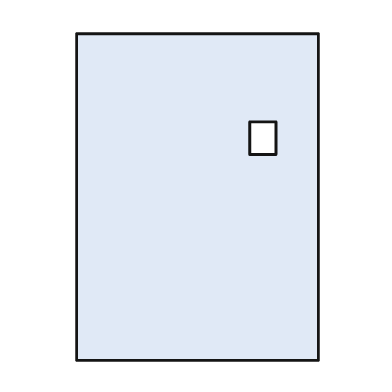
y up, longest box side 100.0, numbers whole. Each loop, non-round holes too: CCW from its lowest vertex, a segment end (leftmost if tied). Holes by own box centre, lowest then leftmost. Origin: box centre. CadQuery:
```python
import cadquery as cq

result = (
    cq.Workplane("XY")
    .moveTo(-37.0, -50.0)
    .lineTo(37.0, -50.0)
    .lineTo(37.0, 50.0)
    .lineTo(-37.0, 50.0)
    .close()
    .moveTo(16.0, 13.0)
    .lineTo(24.0, 13.0)
    .lineTo(24.0, 23.0)
    .lineTo(16.0, 23.0)
    .close()
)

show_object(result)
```